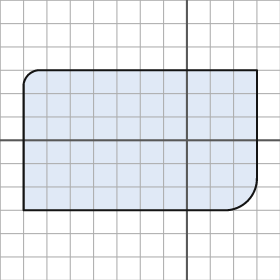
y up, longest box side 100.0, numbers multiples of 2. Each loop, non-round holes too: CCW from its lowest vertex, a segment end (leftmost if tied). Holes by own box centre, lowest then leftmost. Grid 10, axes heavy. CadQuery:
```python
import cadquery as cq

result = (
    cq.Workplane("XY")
    .moveTo(-70.0, -30.0)
    .lineTo(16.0, -30.0)
    .threePointArc((26.0, -26.0), (30.0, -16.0))
    .lineTo(30.0, 30.0)
    .lineTo(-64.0, 30.0)
    .threePointArc((-68.0, 28.0), (-70.0, 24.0))
    .close()
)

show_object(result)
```